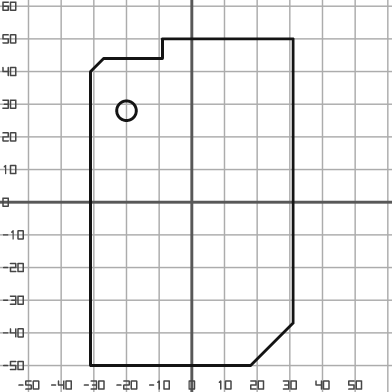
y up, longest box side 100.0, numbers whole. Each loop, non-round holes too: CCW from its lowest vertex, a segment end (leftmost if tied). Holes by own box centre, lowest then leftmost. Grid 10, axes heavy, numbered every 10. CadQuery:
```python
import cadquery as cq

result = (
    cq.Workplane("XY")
    .moveTo(-31.0, -50.0)
    .lineTo(18.0, -50.0)
    .lineTo(31.0, -37.0)
    .lineTo(31.0, 50.0)
    .lineTo(-9.0, 50.0)
    .lineTo(-9.0, 44.0)
    .lineTo(-27.0, 44.0)
    .lineTo(-31.0, 40.0)
    .close()
    .moveTo(-20.0, 28.0)
    .circle(3.0)
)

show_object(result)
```